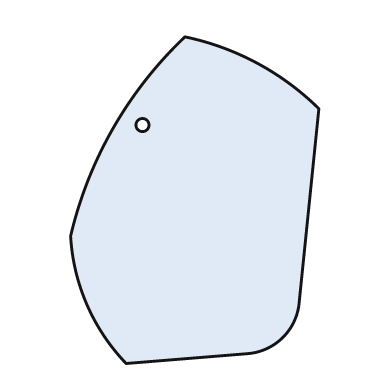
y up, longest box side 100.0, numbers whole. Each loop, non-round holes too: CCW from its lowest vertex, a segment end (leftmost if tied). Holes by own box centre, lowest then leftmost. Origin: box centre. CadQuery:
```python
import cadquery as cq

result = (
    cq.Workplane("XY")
    .moveTo(-21.0, -50.0)
    .lineTo(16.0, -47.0)
    .threePointArc((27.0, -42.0), (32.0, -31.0))
    .lineTo(38.0, 28.0)
    .threePointArc((19.0, 42.0), (-3.0, 50.0))
    .threePointArc((-25.0, 22.0), (-38.0, -11.0))
    .threePointArc((-33.0, -32.0), (-21.0, -50.0))
    .close()
    .moveTo(-16.0, 23.0)
    .circle(2.0)
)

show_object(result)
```